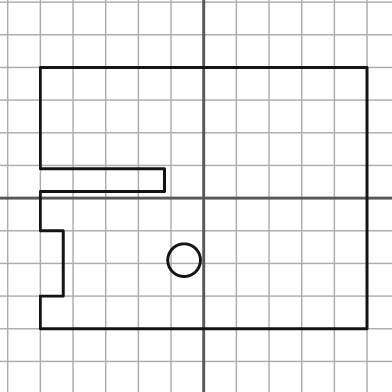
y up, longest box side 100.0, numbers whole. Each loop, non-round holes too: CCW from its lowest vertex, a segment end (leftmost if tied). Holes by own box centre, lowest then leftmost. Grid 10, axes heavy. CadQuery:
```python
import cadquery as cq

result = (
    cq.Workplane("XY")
    .moveTo(-50.0, -40.0)
    .lineTo(50.0, -40.0)
    .lineTo(50.0, 40.0)
    .lineTo(-50.0, 40.0)
    .lineTo(-50.0, 9.0)
    .lineTo(-12.0, 9.0)
    .lineTo(-12.0, 2.0)
    .lineTo(-50.0, 2.0)
    .lineTo(-50.0, -10.0)
    .lineTo(-43.0, -10.0)
    .lineTo(-43.0, -30.0)
    .lineTo(-50.0, -30.0)
    .close()
    .moveTo(-6.0, -19.0)
    .circle(5.0)
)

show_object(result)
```